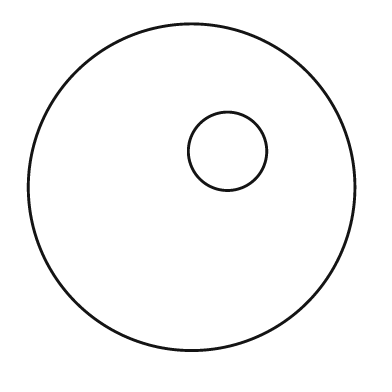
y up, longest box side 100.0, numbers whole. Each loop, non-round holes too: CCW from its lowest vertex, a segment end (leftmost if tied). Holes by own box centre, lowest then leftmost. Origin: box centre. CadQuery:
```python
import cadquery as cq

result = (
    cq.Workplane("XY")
    .moveTo(0.0, 0.0)
    .circle(50.0)
    .moveTo(11.0, 11.0)
    .circle(12.0)
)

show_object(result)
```